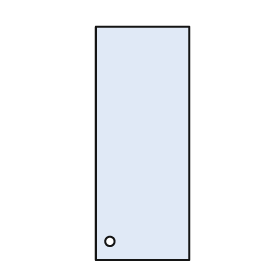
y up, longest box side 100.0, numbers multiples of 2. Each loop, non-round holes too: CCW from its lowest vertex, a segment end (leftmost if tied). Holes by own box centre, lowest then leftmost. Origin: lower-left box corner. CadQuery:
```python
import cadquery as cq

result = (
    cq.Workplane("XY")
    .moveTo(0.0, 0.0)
    .lineTo(40.0, 0.0)
    .lineTo(40.0, 100.0)
    .lineTo(0.0, 100.0)
    .close()
    .moveTo(6.0, 8.0)
    .circle(2.0)
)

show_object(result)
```